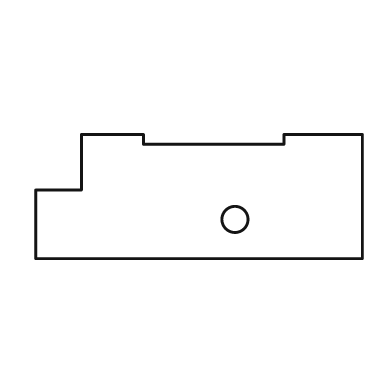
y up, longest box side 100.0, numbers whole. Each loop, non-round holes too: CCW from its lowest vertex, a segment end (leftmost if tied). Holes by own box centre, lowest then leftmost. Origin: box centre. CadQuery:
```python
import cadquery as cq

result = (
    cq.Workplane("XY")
    .moveTo(-50.0, -19.0)
    .lineTo(50.0, -19.0)
    .lineTo(50.0, 19.0)
    .lineTo(26.0, 19.0)
    .lineTo(26.0, 16.0)
    .lineTo(-17.0, 16.0)
    .lineTo(-17.0, 19.0)
    .lineTo(-36.0, 19.0)
    .lineTo(-36.0, 2.0)
    .lineTo(-50.0, 2.0)
    .close()
    .moveTo(11.0, -7.0)
    .circle(4.0)
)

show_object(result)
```